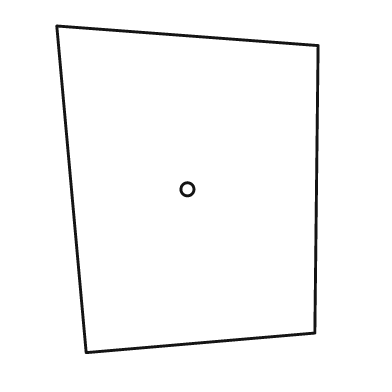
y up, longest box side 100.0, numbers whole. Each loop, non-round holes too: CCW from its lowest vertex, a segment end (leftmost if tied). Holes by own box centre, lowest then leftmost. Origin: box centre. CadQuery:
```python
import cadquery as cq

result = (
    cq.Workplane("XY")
    .moveTo(-31.0, -50.0)
    .lineTo(39.0, -44.0)
    .lineTo(40.0, 44.0)
    .lineTo(-40.0, 50.0)
    .close()
    .moveTo(0.0, 0.0)
    .circle(2.0)
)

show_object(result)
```